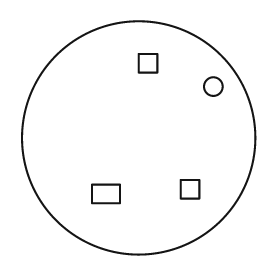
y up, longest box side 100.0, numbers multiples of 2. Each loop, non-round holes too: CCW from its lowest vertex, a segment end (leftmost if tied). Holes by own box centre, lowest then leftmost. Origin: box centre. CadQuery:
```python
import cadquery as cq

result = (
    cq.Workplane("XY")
    .moveTo(0.0, 0.0)
    .circle(50.0)
    .moveTo(-20.0, -28.0)
    .lineTo(-8.0, -28.0)
    .lineTo(-8.0, -20.0)
    .lineTo(-20.0, -20.0)
    .close()
    .moveTo(18.0, -26.0)
    .lineTo(26.0, -26.0)
    .lineTo(26.0, -18.0)
    .lineTo(18.0, -18.0)
    .close()
    .moveTo(32.0, 22.0)
    .circle(4.0)
    .moveTo(0.0, 28.0)
    .lineTo(8.0, 28.0)
    .lineTo(8.0, 36.0)
    .lineTo(0.0, 36.0)
    .close()
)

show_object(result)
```